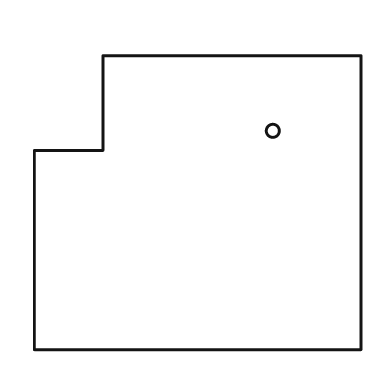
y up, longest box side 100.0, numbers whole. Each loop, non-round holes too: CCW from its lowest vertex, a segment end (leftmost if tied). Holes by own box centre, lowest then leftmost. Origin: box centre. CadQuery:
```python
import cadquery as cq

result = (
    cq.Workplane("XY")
    .moveTo(-50.0, -45.0)
    .lineTo(50.0, -45.0)
    .lineTo(50.0, 45.0)
    .lineTo(-29.0, 45.0)
    .lineTo(-29.0, 16.0)
    .lineTo(-50.0, 16.0)
    .close()
    .moveTo(23.0, 22.0)
    .circle(2.0)
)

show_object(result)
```